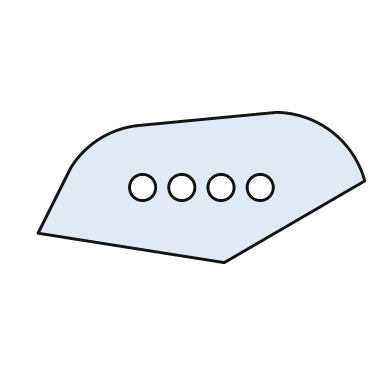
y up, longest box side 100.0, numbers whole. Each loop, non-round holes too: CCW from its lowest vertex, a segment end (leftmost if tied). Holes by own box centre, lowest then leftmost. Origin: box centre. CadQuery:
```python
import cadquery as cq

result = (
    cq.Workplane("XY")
    .moveTo(7.0, -23.0)
    .lineTo(50.0, 2.0)
    .threePointArc((40.0, 17.0), (23.0, 23.0))
    .lineTo(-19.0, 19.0)
    .threePointArc((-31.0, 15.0), (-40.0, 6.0))
    .lineTo(-50.0, -14.0)
    .close()
    .moveTo(-18.0, 0.0)
    .circle(4.0)
    .moveTo(-6.0, 0.0)
    .circle(4.0)
    .moveTo(6.0, 0.0)
    .circle(4.0)
    .moveTo(18.0, 0.0)
    .circle(4.0)
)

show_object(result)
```